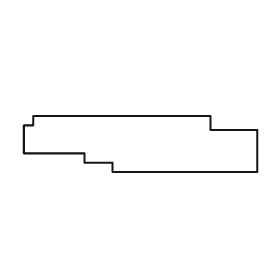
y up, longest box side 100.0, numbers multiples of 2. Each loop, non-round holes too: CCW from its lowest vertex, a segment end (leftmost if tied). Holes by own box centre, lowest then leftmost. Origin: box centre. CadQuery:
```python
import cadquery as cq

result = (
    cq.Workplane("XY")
    .moveTo(-12.0, -12.0)
    .lineTo(50.0, -12.0)
    .lineTo(50.0, 6.0)
    .lineTo(30.0, 6.0)
    .lineTo(30.0, 12.0)
    .lineTo(-46.0, 12.0)
    .lineTo(-46.0, 8.0)
    .lineTo(-50.0, 8.0)
    .lineTo(-50.0, -4.0)
    .lineTo(-24.0, -4.0)
    .lineTo(-24.0, -8.0)
    .lineTo(-12.0, -8.0)
    .close()
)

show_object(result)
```